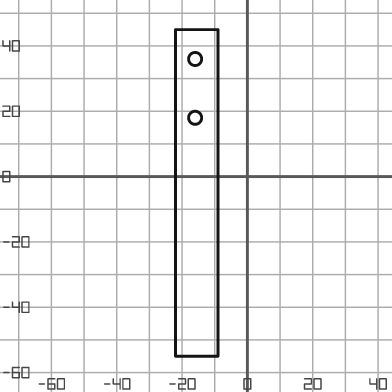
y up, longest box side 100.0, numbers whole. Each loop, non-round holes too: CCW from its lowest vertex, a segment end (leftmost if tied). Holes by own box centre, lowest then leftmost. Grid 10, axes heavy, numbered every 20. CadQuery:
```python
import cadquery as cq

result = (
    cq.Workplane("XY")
    .moveTo(-22.0, -55.0)
    .lineTo(-9.0, -55.0)
    .lineTo(-9.0, 45.0)
    .lineTo(-22.0, 45.0)
    .close()
    .moveTo(-16.0, 18.0)
    .circle(2.0)
    .moveTo(-16.0, 36.0)
    .circle(2.0)
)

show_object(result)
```